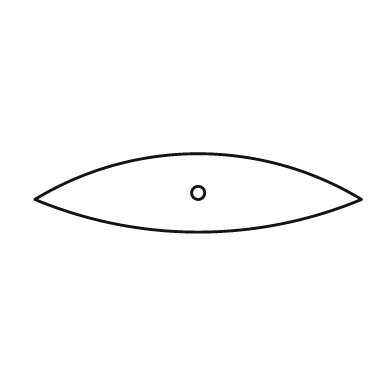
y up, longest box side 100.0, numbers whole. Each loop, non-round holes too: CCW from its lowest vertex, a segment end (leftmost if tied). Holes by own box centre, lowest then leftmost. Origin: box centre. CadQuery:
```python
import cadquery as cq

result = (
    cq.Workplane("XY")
    .moveTo(-50.0, -2.0)
    .threePointArc((0.0, -12.0), (50.0, -2.0))
    .threePointArc((0.0, 12.0), (-50.0, -2.0))
    .close()
    .moveTo(0.0, 0.0)
    .circle(2.0)
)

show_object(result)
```